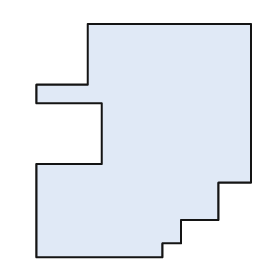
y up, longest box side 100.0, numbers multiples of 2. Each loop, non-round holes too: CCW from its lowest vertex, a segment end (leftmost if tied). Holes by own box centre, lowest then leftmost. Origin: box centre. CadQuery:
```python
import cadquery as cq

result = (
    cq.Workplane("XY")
    .moveTo(-46.0, -50.0)
    .lineTo(8.0, -50.0)
    .lineTo(8.0, -44.0)
    .lineTo(16.0, -44.0)
    .lineTo(16.0, -34.0)
    .lineTo(32.0, -34.0)
    .lineTo(32.0, -18.0)
    .lineTo(46.0, -18.0)
    .lineTo(46.0, 50.0)
    .lineTo(-24.0, 50.0)
    .lineTo(-24.0, 24.0)
    .lineTo(-46.0, 24.0)
    .lineTo(-46.0, 16.0)
    .lineTo(-18.0, 16.0)
    .lineTo(-18.0, -10.0)
    .lineTo(-46.0, -10.0)
    .close()
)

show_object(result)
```